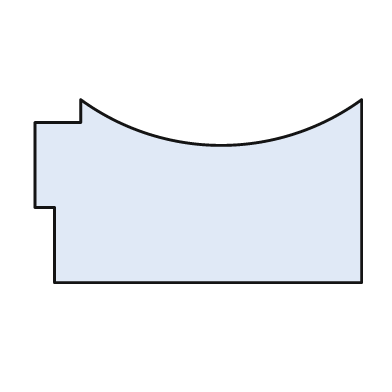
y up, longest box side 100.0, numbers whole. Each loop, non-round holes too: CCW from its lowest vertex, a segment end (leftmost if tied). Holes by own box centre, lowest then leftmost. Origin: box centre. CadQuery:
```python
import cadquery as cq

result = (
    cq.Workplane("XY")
    .moveTo(-44.0, -28.0)
    .lineTo(50.0, -28.0)
    .lineTo(50.0, 28.0)
    .threePointArc((7.0, 14.0), (-36.0, 28.0))
    .lineTo(-36.0, 21.0)
    .lineTo(-50.0, 21.0)
    .lineTo(-50.0, -5.0)
    .lineTo(-44.0, -5.0)
    .close()
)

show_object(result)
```